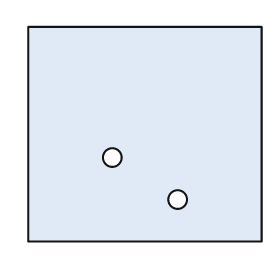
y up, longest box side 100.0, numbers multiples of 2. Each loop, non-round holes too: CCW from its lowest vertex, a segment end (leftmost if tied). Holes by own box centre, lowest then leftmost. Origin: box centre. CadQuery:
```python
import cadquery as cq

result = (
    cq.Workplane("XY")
    .moveTo(-50.0, -46.0)
    .lineTo(50.0, -46.0)
    .lineTo(50.0, 46.0)
    .lineTo(-50.0, 46.0)
    .close()
    .moveTo(14.0, -28.0)
    .circle(4.0)
    .moveTo(-14.0, -10.0)
    .circle(4.0)
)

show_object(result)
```